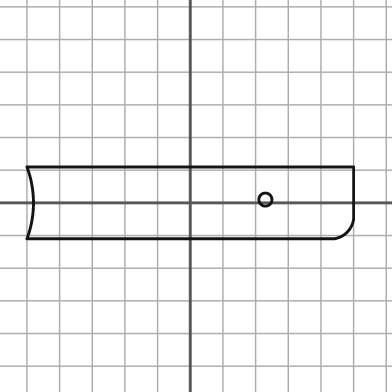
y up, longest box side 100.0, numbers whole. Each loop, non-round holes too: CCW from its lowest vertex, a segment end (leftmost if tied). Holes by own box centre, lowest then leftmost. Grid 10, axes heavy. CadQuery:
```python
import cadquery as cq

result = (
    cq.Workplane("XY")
    .moveTo(-50.0, -11.0)
    .lineTo(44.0, -11.0)
    .threePointArc((48.0, -9.0), (50.0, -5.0))
    .lineTo(50.0, 11.0)
    .lineTo(-50.0, 11.0)
    .threePointArc((-48.0, 0.0), (-50.0, -11.0))
    .close()
    .moveTo(23.0, 1.0)
    .circle(2.0)
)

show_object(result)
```